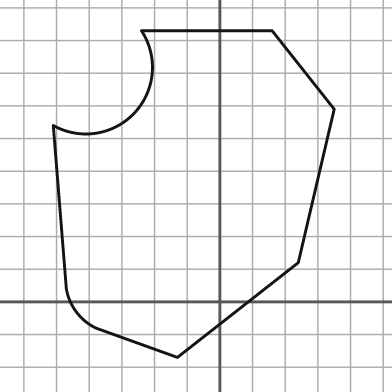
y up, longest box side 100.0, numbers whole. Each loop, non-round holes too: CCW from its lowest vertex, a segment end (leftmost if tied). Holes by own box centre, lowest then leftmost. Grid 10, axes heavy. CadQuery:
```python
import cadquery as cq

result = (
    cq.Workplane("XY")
    .moveTo(-13.0, -17.0)
    .lineTo(24.0, 12.0)
    .lineTo(35.0, 59.0)
    .lineTo(16.0, 83.0)
    .lineTo(-24.0, 83.0)
    .threePointArc((-26.0, 58.0), (-51.0, 54.0))
    .lineTo(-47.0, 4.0)
    .threePointArc((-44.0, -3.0), (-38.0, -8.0))
    .close()
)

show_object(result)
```